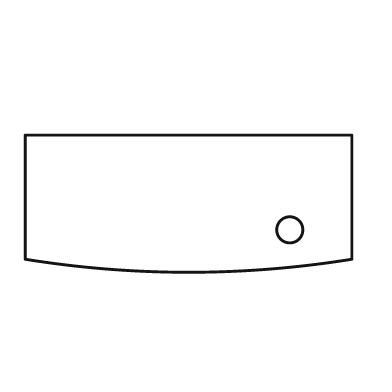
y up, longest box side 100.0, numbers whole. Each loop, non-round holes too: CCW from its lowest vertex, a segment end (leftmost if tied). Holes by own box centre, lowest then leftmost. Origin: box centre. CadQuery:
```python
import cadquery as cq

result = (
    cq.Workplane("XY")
    .moveTo(-50.0, -17.0)
    .threePointArc((0.0, -21.0), (50.0, -17.0))
    .lineTo(50.0, 21.0)
    .lineTo(-50.0, 21.0)
    .close()
    .moveTo(31.0, -8.0)
    .circle(4.0)
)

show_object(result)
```